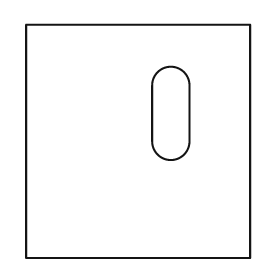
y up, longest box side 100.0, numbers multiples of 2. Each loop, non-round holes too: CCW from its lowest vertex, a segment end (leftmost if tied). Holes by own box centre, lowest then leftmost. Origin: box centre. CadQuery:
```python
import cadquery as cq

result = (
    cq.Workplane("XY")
    .moveTo(-48.0, -50.0)
    .lineTo(48.0, -50.0)
    .lineTo(48.0, 50.0)
    .lineTo(-48.0, 50.0)
    .close()
    .moveTo(6.0, 0.0)
    .threePointArc((14.0, -8.0), (22.0, 0.0))
    .lineTo(22.0, 24.0)
    .threePointArc((14.0, 32.0), (6.0, 24.0))
    .close()
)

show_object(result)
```